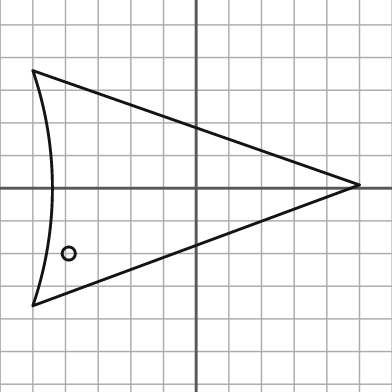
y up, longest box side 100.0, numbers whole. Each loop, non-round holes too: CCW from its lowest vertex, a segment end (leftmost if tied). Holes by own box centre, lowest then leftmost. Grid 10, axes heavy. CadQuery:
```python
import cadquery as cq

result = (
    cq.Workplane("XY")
    .moveTo(-50.0, -36.0)
    .lineTo(50.0, 1.0)
    .lineTo(-50.0, 36.0)
    .threePointArc((-44.0, 0.0), (-50.0, -36.0))
    .close()
    .moveTo(-39.0, -20.0)
    .circle(2.0)
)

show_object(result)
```